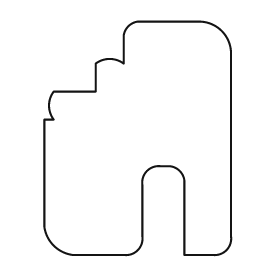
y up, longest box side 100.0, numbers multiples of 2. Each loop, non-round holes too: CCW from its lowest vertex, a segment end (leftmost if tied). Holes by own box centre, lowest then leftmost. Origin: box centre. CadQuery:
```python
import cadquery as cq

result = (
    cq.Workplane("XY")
    .moveTo(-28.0, -50.0)
    .lineTo(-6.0, -50.0)
    .threePointArc((0.0, -48.0), (2.0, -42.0))
    .lineTo(2.0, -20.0)
    .threePointArc((4.0, -14.0), (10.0, -12.0))
    .lineTo(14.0, -12.0)
    .threePointArc((18.0, -14.0), (20.0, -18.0))
    .lineTo(20.0, -50.0)
    .lineTo(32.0, -50.0)
    .threePointArc((38.0, -48.0), (40.0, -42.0))
    .lineTo(40.0, 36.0)
    .threePointArc((36.0, 46.0), (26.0, 50.0))
    .lineTo(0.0, 50.0)
    .threePointArc((-4.0, 48.0), (-6.0, 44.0))
    .lineTo(-6.0, 32.0)
    .threePointArc((-12.0, 34.0), (-18.0, 32.0))
    .lineTo(-18.0, 20.0)
    .lineTo(-36.0, 20.0)
    .threePointArc((-38.0, 14.0), (-36.0, 8.0))
    .lineTo(-40.0, 8.0)
    .lineTo(-40.0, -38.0)
    .threePointArc((-36.0, -46.0), (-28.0, -50.0))
    .close()
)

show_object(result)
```